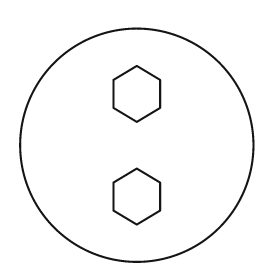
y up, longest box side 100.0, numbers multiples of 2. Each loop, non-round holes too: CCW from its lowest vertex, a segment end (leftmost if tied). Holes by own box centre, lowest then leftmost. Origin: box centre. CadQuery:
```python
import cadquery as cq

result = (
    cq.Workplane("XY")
    .moveTo(0.0, 0.0)
    .circle(50.0)
    .moveTo(0.0, -34.0)
    .lineTo(10.0, -28.0)
    .lineTo(10.0, -16.0)
    .lineTo(0.0, -10.0)
    .lineTo(-10.0, -16.0)
    .lineTo(-10.0, -28.0)
    .close()
    .moveTo(0.0, 10.0)
    .lineTo(10.0, 16.0)
    .lineTo(10.0, 28.0)
    .lineTo(0.0, 34.0)
    .lineTo(-10.0, 28.0)
    .lineTo(-10.0, 16.0)
    .close()
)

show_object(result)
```